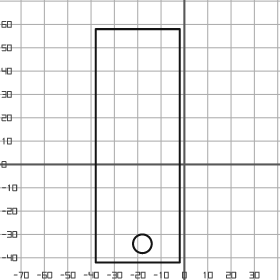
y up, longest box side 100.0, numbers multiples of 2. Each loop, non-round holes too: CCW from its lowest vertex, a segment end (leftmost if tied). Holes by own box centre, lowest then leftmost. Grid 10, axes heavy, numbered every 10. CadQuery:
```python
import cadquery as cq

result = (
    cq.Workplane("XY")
    .moveTo(-38.0, -42.0)
    .lineTo(-2.0, -42.0)
    .lineTo(-2.0, 58.0)
    .lineTo(-38.0, 58.0)
    .close()
    .moveTo(-18.0, -34.0)
    .circle(4.0)
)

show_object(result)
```